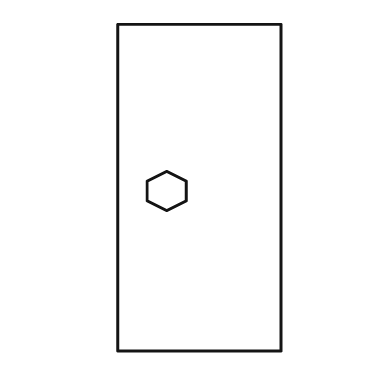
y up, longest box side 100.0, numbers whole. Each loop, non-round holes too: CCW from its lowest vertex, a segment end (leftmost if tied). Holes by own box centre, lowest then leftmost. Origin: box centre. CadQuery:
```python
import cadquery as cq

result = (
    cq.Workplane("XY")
    .moveTo(-25.0, -50.0)
    .lineTo(25.0, -50.0)
    .lineTo(25.0, 50.0)
    .lineTo(-25.0, 50.0)
    .close()
    .moveTo(-10.0, -7.0)
    .lineTo(-4.0, -4.0)
    .lineTo(-4.0, 2.0)
    .lineTo(-10.0, 5.0)
    .lineTo(-16.0, 2.0)
    .lineTo(-16.0, -4.0)
    .close()
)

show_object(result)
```